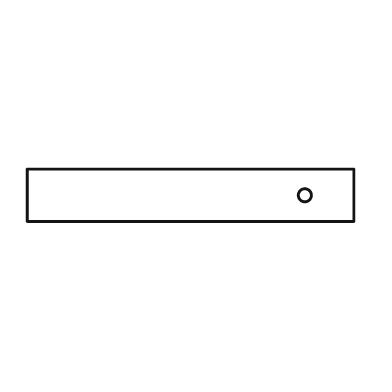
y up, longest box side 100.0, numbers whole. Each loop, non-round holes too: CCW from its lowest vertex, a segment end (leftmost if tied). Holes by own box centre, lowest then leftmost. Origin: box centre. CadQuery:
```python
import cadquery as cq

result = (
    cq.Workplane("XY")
    .moveTo(-50.0, -8.0)
    .lineTo(50.0, -8.0)
    .lineTo(50.0, 8.0)
    .lineTo(-50.0, 8.0)
    .close()
    .moveTo(35.0, 0.0)
    .circle(2.0)
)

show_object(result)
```